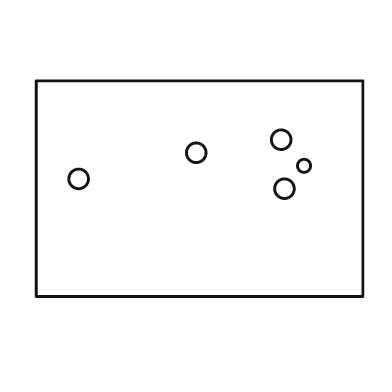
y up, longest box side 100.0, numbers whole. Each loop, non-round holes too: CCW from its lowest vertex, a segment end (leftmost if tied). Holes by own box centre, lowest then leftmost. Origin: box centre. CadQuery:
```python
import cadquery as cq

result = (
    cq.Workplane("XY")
    .moveTo(-50.0, -33.0)
    .lineTo(50.0, -33.0)
    .lineTo(50.0, 33.0)
    .lineTo(-50.0, 33.0)
    .close()
    .moveTo(26.0, 0.0)
    .circle(3.0)
    .moveTo(-37.0, 3.0)
    .circle(3.0)
    .moveTo(32.0, 7.0)
    .circle(2.0)
    .moveTo(-1.0, 11.0)
    .circle(3.0)
    .moveTo(25.0, 15.0)
    .circle(3.0)
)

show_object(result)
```